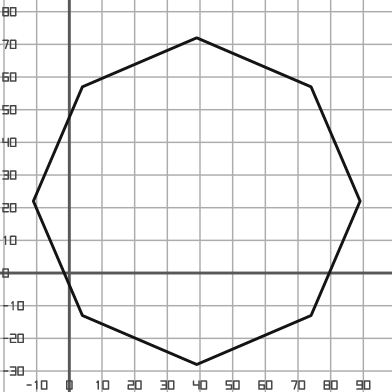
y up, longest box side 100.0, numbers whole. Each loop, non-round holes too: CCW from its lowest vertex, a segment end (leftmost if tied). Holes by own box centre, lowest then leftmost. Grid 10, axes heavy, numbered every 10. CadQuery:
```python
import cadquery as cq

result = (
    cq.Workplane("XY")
    .moveTo(39.0, -28.0)
    .lineTo(74.0, -13.0)
    .lineTo(89.0, 22.0)
    .lineTo(74.0, 57.0)
    .lineTo(39.0, 72.0)
    .lineTo(4.0, 57.0)
    .lineTo(-11.0, 22.0)
    .lineTo(4.0, -13.0)
    .close()
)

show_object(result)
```